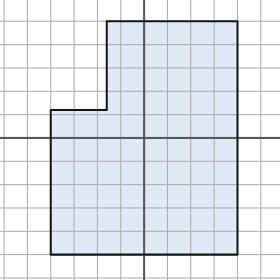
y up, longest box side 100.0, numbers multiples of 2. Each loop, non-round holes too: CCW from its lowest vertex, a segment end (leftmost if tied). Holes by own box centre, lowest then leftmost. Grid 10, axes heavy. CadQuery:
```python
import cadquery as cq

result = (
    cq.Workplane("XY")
    .moveTo(-40.0, -50.0)
    .lineTo(40.0, -50.0)
    .lineTo(40.0, 50.0)
    .lineTo(-16.0, 50.0)
    .lineTo(-16.0, 12.0)
    .lineTo(-40.0, 12.0)
    .close()
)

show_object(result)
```